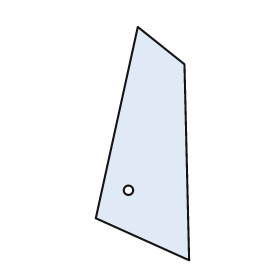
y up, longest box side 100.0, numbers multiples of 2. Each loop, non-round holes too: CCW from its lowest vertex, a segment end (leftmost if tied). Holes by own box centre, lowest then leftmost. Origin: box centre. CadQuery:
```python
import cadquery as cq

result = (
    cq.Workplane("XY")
    .moveTo(20.0, -50.0)
    .lineTo(18.0, 34.0)
    .lineTo(-2.0, 50.0)
    .lineTo(-20.0, -32.0)
    .close()
    .moveTo(-6.0, -20.0)
    .circle(2.0)
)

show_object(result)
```